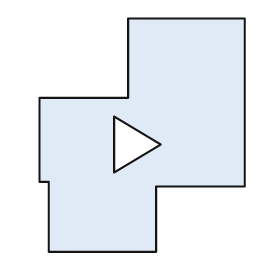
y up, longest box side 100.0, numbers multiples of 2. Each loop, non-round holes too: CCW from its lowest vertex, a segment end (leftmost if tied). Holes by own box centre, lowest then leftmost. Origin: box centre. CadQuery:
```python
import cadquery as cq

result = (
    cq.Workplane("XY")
    .moveTo(-40.0, -50.0)
    .lineTo(6.0, -50.0)
    .lineTo(6.0, -22.0)
    .lineTo(44.0, -22.0)
    .lineTo(44.0, 50.0)
    .lineTo(-6.0, 50.0)
    .lineTo(-6.0, 16.0)
    .lineTo(-44.0, 16.0)
    .lineTo(-44.0, -20.0)
    .lineTo(-40.0, -20.0)
    .close()
    .moveTo(-12.0, -16.0)
    .lineTo(8.0, -4.0)
    .lineTo(-12.0, 8.0)
    .close()
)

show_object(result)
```